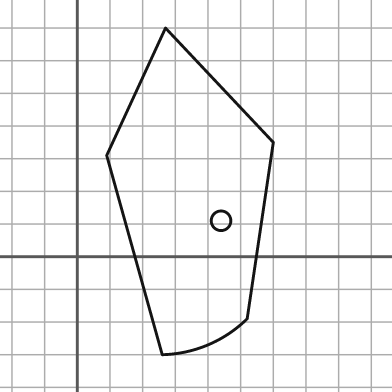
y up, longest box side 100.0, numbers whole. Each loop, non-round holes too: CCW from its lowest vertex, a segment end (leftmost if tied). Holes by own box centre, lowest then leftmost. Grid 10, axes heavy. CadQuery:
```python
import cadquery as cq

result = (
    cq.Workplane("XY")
    .moveTo(26.0, -30.0)
    .threePointArc((40.0, -27.0), (52.0, -19.0))
    .lineTo(60.0, 35.0)
    .lineTo(27.0, 70.0)
    .lineTo(9.0, 31.0)
    .close()
    .moveTo(44.0, 11.0)
    .circle(3.0)
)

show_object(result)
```